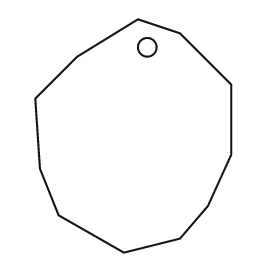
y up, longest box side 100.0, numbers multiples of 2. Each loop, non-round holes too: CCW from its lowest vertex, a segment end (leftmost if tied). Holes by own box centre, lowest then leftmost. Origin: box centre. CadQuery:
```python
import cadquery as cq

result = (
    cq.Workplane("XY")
    .moveTo(-4.0, -50.0)
    .lineTo(20.0, -44.0)
    .lineTo(32.0, -30.0)
    .lineTo(42.0, -8.0)
    .lineTo(42.0, 22.0)
    .lineTo(20.0, 44.0)
    .lineTo(2.0, 50.0)
    .lineTo(-24.0, 34.0)
    .lineTo(-42.0, 16.0)
    .lineTo(-40.0, -14.0)
    .lineTo(-32.0, -34.0)
    .close()
    .moveTo(6.0, 38.0)
    .circle(4.0)
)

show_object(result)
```